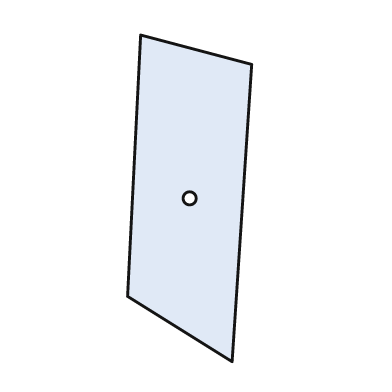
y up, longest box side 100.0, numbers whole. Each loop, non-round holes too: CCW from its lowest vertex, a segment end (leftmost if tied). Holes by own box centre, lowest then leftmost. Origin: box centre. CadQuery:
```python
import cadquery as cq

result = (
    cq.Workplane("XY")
    .moveTo(13.0, -50.0)
    .lineTo(19.0, 41.0)
    .lineTo(-15.0, 50.0)
    .lineTo(-19.0, -30.0)
    .close()
    .moveTo(0.0, 0.0)
    .circle(2.0)
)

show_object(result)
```